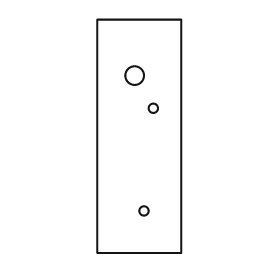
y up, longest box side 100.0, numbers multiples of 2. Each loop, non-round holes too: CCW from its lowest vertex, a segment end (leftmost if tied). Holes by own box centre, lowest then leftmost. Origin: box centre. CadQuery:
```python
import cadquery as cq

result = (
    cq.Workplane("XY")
    .moveTo(-18.0, -50.0)
    .lineTo(18.0, -50.0)
    .lineTo(18.0, 50.0)
    .lineTo(-18.0, 50.0)
    .close()
    .moveTo(2.0, -32.0)
    .circle(2.0)
    .moveTo(6.0, 12.0)
    .circle(2.0)
    .moveTo(-2.0, 26.0)
    .circle(4.0)
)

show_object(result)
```